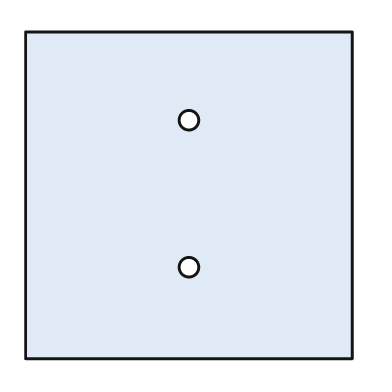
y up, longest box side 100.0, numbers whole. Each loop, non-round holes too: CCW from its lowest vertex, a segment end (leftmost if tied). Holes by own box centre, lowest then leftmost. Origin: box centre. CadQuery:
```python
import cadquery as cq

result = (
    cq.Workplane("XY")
    .moveTo(-50.0, -50.0)
    .lineTo(50.0, -50.0)
    .lineTo(50.0, 50.0)
    .lineTo(-50.0, 50.0)
    .close()
    .moveTo(0.0, -22.0)
    .circle(3.0)
    .moveTo(0.0, 23.0)
    .circle(3.0)
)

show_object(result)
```